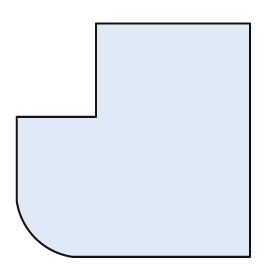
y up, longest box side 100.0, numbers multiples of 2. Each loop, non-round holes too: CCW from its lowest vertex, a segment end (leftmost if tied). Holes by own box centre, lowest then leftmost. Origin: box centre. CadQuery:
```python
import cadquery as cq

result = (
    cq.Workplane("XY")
    .moveTo(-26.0, -50.0)
    .lineTo(50.0, -50.0)
    .lineTo(50.0, 50.0)
    .lineTo(-16.0, 50.0)
    .lineTo(-16.0, 10.0)
    .lineTo(-50.0, 10.0)
    .lineTo(-50.0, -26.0)
    .threePointArc((-42.0, -42.0), (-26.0, -50.0))
    .close()
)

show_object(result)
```